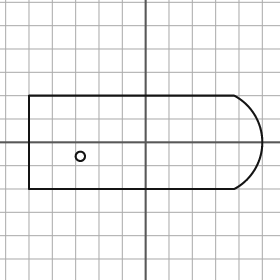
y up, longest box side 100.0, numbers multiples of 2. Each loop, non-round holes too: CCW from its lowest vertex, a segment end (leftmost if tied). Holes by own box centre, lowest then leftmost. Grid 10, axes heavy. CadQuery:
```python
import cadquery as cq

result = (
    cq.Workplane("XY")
    .moveTo(-50.0, -20.0)
    .lineTo(38.0, -20.0)
    .threePointArc((50.0, 0.0), (38.0, 20.0))
    .lineTo(-50.0, 20.0)
    .close()
    .moveTo(-28.0, -6.0)
    .circle(2.0)
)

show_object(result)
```